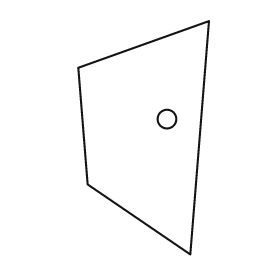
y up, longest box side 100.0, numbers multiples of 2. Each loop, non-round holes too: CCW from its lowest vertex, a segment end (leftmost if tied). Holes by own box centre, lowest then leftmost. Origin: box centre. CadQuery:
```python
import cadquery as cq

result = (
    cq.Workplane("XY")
    .moveTo(20.0, -50.0)
    .lineTo(28.0, 50.0)
    .lineTo(-28.0, 30.0)
    .lineTo(-24.0, -20.0)
    .close()
    .moveTo(10.0, 8.0)
    .circle(4.0)
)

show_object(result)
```